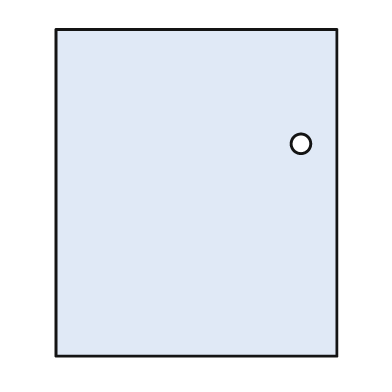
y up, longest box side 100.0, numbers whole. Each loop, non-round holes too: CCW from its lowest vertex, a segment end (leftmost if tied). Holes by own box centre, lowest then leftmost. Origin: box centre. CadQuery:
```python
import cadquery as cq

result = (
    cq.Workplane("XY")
    .moveTo(-43.0, -50.0)
    .lineTo(43.0, -50.0)
    .lineTo(43.0, 50.0)
    .lineTo(-43.0, 50.0)
    .close()
    .moveTo(32.0, 15.0)
    .circle(3.0)
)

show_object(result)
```